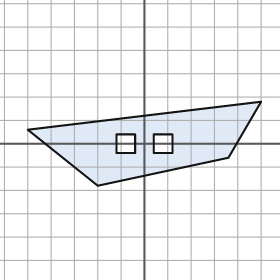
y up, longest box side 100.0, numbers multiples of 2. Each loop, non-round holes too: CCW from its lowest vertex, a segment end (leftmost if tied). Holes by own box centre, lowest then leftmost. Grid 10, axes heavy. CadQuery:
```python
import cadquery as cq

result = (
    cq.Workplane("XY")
    .moveTo(-20.0, -18.0)
    .lineTo(36.0, -6.0)
    .lineTo(50.0, 18.0)
    .lineTo(-50.0, 6.0)
    .close()
    .moveTo(-12.0, -4.0)
    .lineTo(-4.0, -4.0)
    .lineTo(-4.0, 4.0)
    .lineTo(-12.0, 4.0)
    .close()
    .moveTo(4.0, -4.0)
    .lineTo(12.0, -4.0)
    .lineTo(12.0, 4.0)
    .lineTo(4.0, 4.0)
    .close()
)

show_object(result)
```